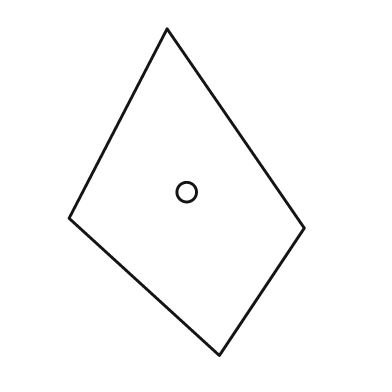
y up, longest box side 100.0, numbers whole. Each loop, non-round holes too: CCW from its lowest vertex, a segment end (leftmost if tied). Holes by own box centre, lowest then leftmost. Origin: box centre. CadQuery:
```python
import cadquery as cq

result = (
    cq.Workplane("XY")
    .moveTo(10.0, -50.0)
    .lineTo(36.0, -11.0)
    .lineTo(-6.0, 50.0)
    .lineTo(-36.0, -8.0)
    .close()
    .moveTo(0.0, 0.0)
    .circle(3.0)
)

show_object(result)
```